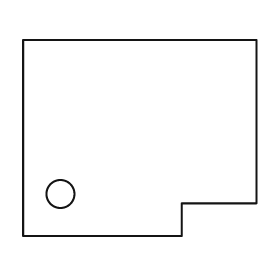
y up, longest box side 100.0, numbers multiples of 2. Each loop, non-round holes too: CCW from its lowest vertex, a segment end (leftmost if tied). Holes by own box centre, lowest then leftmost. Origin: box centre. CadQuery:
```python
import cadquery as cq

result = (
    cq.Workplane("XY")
    .moveTo(-50.0, -42.0)
    .lineTo(18.0, -42.0)
    .lineTo(18.0, -28.0)
    .lineTo(50.0, -28.0)
    .lineTo(50.0, 42.0)
    .lineTo(-50.0, 42.0)
    .close()
    .moveTo(-34.0, -24.0)
    .circle(6.0)
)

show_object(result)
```